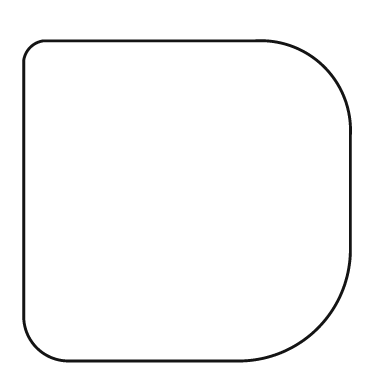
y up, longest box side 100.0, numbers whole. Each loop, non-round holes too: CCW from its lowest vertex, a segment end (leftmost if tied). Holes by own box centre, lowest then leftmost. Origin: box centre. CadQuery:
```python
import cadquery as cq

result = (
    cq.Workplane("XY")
    .moveTo(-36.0, -49.0)
    .lineTo(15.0, -49.0)
    .threePointArc((40.0, -39.0), (50.0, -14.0))
    .lineTo(50.0, 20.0)
    .threePointArc((42.0, 41.0), (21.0, 49.0))
    .lineTo(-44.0, 49.0)
    .threePointArc((-48.0, 47.0), (-50.0, 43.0))
    .lineTo(-50.0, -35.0)
    .threePointArc((-46.0, -45.0), (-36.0, -49.0))
    .close()
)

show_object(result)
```